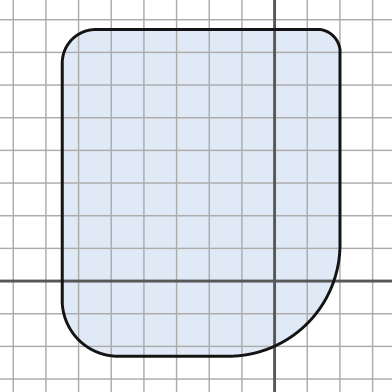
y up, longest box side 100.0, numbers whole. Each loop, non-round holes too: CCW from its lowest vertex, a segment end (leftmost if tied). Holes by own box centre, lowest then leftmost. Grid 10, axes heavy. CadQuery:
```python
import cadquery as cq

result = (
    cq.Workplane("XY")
    .moveTo(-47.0, -23.0)
    .lineTo(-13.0, -23.0)
    .threePointArc((10.0, -13.0), (20.0, 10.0))
    .lineTo(20.0, 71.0)
    .threePointArc((18.0, 75.0), (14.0, 77.0))
    .lineTo(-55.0, 77.0)
    .threePointArc((-62.0, 74.0), (-65.0, 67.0))
    .lineTo(-65.0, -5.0)
    .threePointArc((-60.0, -18.0), (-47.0, -23.0))
    .close()
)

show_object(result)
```